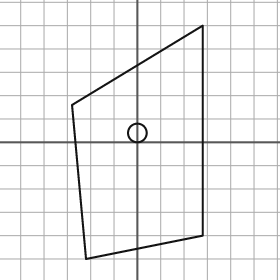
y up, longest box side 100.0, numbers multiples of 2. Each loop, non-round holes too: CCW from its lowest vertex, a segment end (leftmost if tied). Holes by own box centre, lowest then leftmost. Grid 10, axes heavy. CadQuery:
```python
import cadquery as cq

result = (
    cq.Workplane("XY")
    .moveTo(-22.0, -50.0)
    .lineTo(28.0, -40.0)
    .lineTo(28.0, 50.0)
    .lineTo(-28.0, 16.0)
    .close()
    .moveTo(0.0, 4.0)
    .circle(4.0)
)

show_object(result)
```